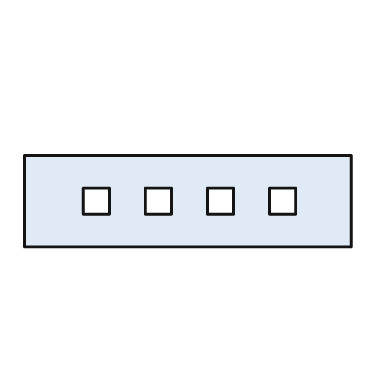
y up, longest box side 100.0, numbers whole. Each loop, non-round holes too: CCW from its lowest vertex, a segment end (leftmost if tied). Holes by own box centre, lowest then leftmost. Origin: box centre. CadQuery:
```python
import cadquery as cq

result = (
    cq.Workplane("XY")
    .moveTo(-50.0, -14.0)
    .lineTo(50.0, -14.0)
    .lineTo(50.0, 14.0)
    .lineTo(-50.0, 14.0)
    .close()
    .moveTo(-32.0, -4.0)
    .lineTo(-24.0, -4.0)
    .lineTo(-24.0, 4.0)
    .lineTo(-32.0, 4.0)
    .close()
    .moveTo(-13.0, -4.0)
    .lineTo(-5.0, -4.0)
    .lineTo(-5.0, 4.0)
    .lineTo(-13.0, 4.0)
    .close()
    .moveTo(6.0, -4.0)
    .lineTo(14.0, -4.0)
    .lineTo(14.0, 4.0)
    .lineTo(6.0, 4.0)
    .close()
    .moveTo(25.0, -4.0)
    .lineTo(33.0, -4.0)
    .lineTo(33.0, 4.0)
    .lineTo(25.0, 4.0)
    .close()
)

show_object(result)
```